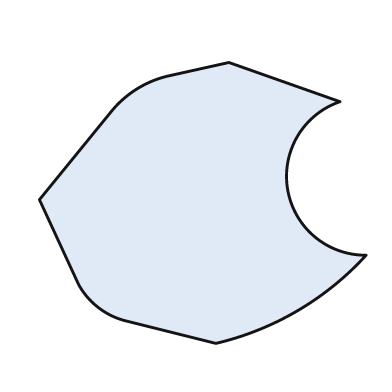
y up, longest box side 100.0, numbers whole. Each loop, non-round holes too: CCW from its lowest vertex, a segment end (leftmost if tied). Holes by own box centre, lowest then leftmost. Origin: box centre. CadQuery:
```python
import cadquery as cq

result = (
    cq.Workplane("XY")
    .moveTo(4.0, -43.0)
    .threePointArc((29.0, -33.0), (50.0, -16.0))
    .threePointArc((26.0, 4.0), (42.0, 31.0))
    .lineTo(8.0, 43.0)
    .lineTo(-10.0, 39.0)
    .threePointArc((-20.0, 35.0), (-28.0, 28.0))
    .lineTo(-50.0, 1.0)
    .lineTo(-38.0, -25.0)
    .threePointArc((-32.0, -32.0), (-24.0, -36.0))
    .close()
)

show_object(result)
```